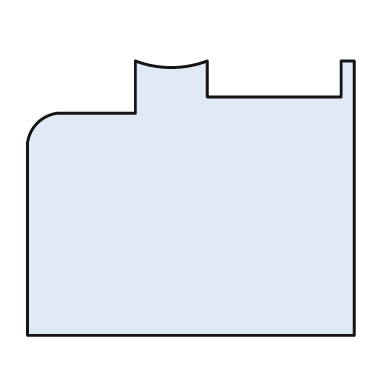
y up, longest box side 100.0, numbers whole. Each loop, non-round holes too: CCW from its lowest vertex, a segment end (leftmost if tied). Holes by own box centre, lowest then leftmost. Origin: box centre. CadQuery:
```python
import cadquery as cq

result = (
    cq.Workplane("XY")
    .moveTo(-50.0, -42.0)
    .lineTo(50.0, -42.0)
    .lineTo(50.0, 42.0)
    .lineTo(46.0, 42.0)
    .lineTo(46.0, 31.0)
    .lineTo(5.0, 31.0)
    .lineTo(5.0, 42.0)
    .threePointArc((-6.0, 40.0), (-17.0, 42.0))
    .lineTo(-17.0, 26.0)
    .lineTo(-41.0, 26.0)
    .threePointArc((-47.0, 23.0), (-50.0, 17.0))
    .close()
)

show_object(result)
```